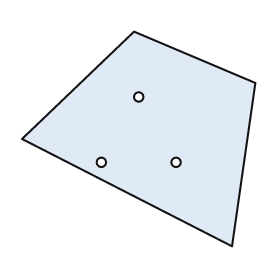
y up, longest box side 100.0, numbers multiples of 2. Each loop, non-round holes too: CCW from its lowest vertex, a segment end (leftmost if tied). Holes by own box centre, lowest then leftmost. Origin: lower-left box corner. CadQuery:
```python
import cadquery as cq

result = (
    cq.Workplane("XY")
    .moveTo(90.0, 0.0)
    .lineTo(100.0, 70.0)
    .lineTo(48.0, 92.0)
    .lineTo(0.0, 46.0)
    .close()
    .moveTo(34.0, 36.0)
    .circle(2.0)
    .moveTo(66.0, 36.0)
    .circle(2.0)
    .moveTo(50.0, 64.0)
    .circle(2.0)
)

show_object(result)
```